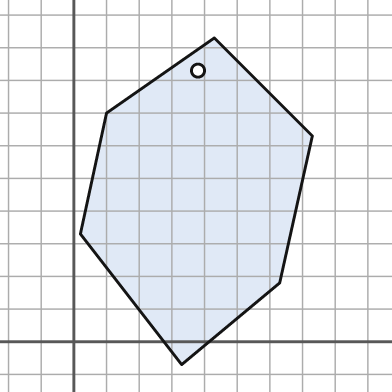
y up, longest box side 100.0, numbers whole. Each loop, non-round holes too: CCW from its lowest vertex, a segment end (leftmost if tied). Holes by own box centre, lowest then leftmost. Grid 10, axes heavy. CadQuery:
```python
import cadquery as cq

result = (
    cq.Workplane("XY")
    .moveTo(33.0, -7.0)
    .lineTo(63.0, 18.0)
    .lineTo(73.0, 63.0)
    .lineTo(43.0, 93.0)
    .lineTo(10.0, 70.0)
    .lineTo(2.0, 33.0)
    .close()
    .moveTo(38.0, 83.0)
    .circle(2.0)
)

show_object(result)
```